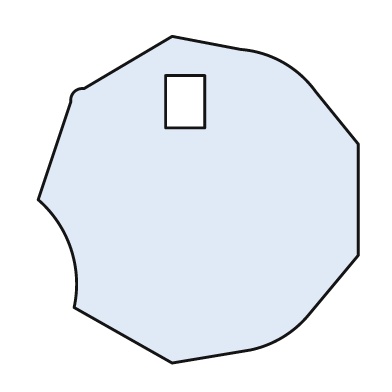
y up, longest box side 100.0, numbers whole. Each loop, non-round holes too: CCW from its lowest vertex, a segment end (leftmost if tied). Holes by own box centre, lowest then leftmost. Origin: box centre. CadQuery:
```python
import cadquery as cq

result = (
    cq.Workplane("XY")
    .moveTo(-8.0, -50.0)
    .lineTo(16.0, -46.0)
    .threePointArc((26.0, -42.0), (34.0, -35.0))
    .lineTo(49.0, -17.0)
    .lineTo(49.0, 17.0)
    .lineTo(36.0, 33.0)
    .threePointArc((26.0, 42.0), (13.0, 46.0))
    .lineTo(-8.0, 50.0)
    .lineTo(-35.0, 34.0)
    .threePointArc((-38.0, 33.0), (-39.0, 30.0))
    .lineTo(-49.0, 0.0)
    .threePointArc((-39.0, -15.0), (-38.0, -33.0))
    .close()
    .moveTo(-10.0, 22.0)
    .lineTo(2.0, 22.0)
    .lineTo(2.0, 38.0)
    .lineTo(-10.0, 38.0)
    .close()
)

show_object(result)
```